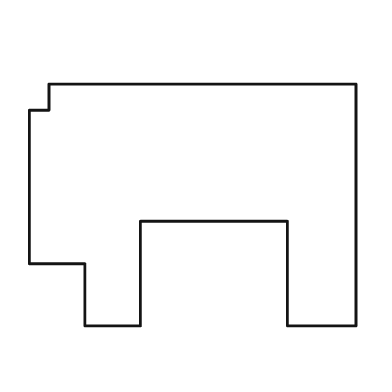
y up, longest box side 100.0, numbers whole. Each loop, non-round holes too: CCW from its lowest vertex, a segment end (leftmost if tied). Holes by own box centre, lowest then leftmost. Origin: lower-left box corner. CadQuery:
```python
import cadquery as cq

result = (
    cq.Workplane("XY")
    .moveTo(17.0, 0.0)
    .lineTo(34.0, 0.0)
    .lineTo(34.0, 32.0)
    .lineTo(79.0, 32.0)
    .lineTo(79.0, 0.0)
    .lineTo(100.0, 0.0)
    .lineTo(100.0, 74.0)
    .lineTo(6.0, 74.0)
    .lineTo(6.0, 66.0)
    .lineTo(0.0, 66.0)
    .lineTo(0.0, 19.0)
    .lineTo(17.0, 19.0)
    .close()
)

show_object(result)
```